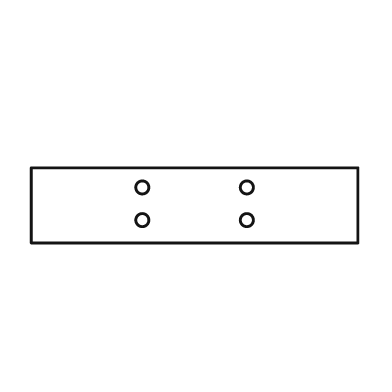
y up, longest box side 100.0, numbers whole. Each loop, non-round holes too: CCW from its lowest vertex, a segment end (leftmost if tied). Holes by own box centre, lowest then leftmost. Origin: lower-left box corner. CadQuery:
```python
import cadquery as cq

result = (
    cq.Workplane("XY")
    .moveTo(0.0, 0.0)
    .lineTo(100.0, 0.0)
    .lineTo(100.0, 23.0)
    .lineTo(0.0, 23.0)
    .close()
    .moveTo(34.0, 7.0)
    .circle(2.0)
    .moveTo(66.0, 7.0)
    .circle(2.0)
    .moveTo(34.0, 17.0)
    .circle(2.0)
    .moveTo(66.0, 17.0)
    .circle(2.0)
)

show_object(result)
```